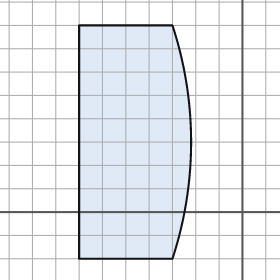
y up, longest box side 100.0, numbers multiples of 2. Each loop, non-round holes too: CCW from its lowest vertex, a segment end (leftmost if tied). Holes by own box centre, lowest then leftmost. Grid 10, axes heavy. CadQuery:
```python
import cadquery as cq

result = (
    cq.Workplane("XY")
    .moveTo(-70.0, -20.0)
    .lineTo(-30.0, -20.0)
    .threePointArc((-22.0, 30.0), (-30.0, 80.0))
    .lineTo(-70.0, 80.0)
    .close()
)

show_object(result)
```